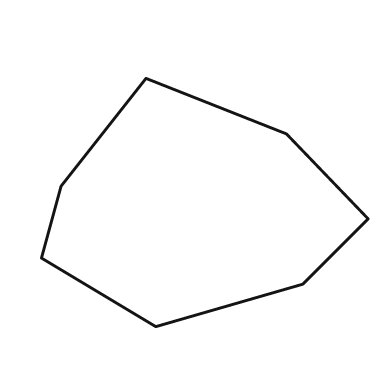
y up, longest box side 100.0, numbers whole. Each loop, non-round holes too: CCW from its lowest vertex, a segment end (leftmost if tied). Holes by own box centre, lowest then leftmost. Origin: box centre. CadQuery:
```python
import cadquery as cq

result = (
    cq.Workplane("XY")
    .moveTo(-15.0, -38.0)
    .lineTo(30.0, -25.0)
    .lineTo(50.0, -5.0)
    .lineTo(25.0, 21.0)
    .lineTo(-18.0, 38.0)
    .lineTo(-44.0, 5.0)
    .lineTo(-50.0, -17.0)
    .close()
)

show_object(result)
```